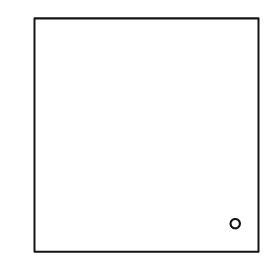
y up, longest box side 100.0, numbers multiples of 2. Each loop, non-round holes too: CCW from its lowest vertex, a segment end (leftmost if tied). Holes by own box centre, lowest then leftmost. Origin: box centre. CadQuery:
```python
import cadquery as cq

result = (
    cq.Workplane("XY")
    .moveTo(-48.0, -50.0)
    .lineTo(48.0, -50.0)
    .lineTo(48.0, 50.0)
    .lineTo(-48.0, 50.0)
    .close()
    .moveTo(38.0, -38.0)
    .circle(2.0)
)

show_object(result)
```